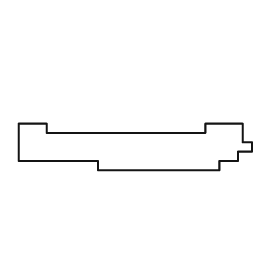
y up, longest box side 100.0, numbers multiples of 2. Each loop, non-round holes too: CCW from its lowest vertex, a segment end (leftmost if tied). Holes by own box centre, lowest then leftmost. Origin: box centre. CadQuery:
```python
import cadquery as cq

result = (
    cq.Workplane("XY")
    .moveTo(-16.0, -10.0)
    .lineTo(36.0, -10.0)
    .lineTo(36.0, -6.0)
    .lineTo(44.0, -6.0)
    .lineTo(44.0, -2.0)
    .lineTo(50.0, -2.0)
    .lineTo(50.0, 2.0)
    .lineTo(46.0, 2.0)
    .lineTo(46.0, 10.0)
    .lineTo(30.0, 10.0)
    .lineTo(30.0, 6.0)
    .lineTo(-38.0, 6.0)
    .lineTo(-38.0, 10.0)
    .lineTo(-50.0, 10.0)
    .lineTo(-50.0, -6.0)
    .lineTo(-16.0, -6.0)
    .close()
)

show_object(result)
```